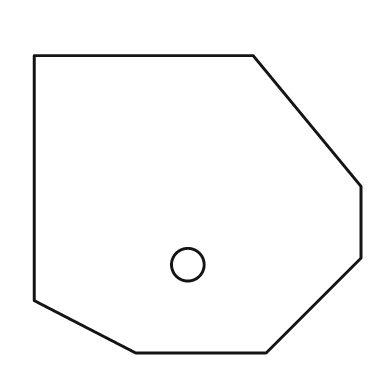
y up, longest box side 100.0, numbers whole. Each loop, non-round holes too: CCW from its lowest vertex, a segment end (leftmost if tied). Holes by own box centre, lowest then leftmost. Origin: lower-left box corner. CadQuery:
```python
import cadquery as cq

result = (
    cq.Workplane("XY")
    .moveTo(31.0, 0.0)
    .lineTo(71.0, 0.0)
    .lineTo(100.0, 29.0)
    .lineTo(100.0, 51.0)
    .lineTo(67.0, 91.0)
    .lineTo(0.0, 91.0)
    .lineTo(0.0, 16.0)
    .close()
    .moveTo(47.0, 27.0)
    .circle(5.0)
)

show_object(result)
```